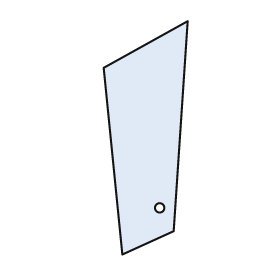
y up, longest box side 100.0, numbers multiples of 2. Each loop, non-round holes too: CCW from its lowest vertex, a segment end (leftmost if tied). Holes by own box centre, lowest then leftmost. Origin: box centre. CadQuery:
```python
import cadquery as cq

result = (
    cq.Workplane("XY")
    .moveTo(-10.0, -50.0)
    .lineTo(12.0, -40.0)
    .lineTo(18.0, 50.0)
    .lineTo(-18.0, 30.0)
    .close()
    .moveTo(6.0, -30.0)
    .circle(2.0)
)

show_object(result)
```